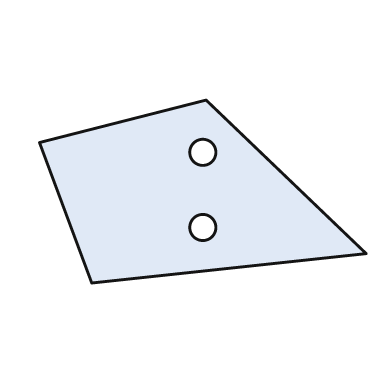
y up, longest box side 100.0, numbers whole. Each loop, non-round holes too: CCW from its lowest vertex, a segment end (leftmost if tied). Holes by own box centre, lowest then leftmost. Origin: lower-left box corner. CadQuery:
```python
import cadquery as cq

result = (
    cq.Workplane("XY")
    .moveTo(16.0, 0.0)
    .lineTo(100.0, 9.0)
    .lineTo(51.0, 56.0)
    .lineTo(0.0, 43.0)
    .close()
    .moveTo(50.0, 17.0)
    .circle(4.0)
    .moveTo(50.0, 40.0)
    .circle(4.0)
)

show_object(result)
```